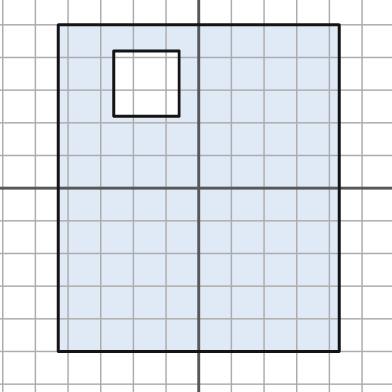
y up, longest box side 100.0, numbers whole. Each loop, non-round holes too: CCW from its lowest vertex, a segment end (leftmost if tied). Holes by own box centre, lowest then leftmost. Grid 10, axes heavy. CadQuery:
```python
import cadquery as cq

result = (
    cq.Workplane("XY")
    .moveTo(-43.0, -50.0)
    .lineTo(43.0, -50.0)
    .lineTo(43.0, 50.0)
    .lineTo(-43.0, 50.0)
    .close()
    .moveTo(-26.0, 22.0)
    .lineTo(-6.0, 22.0)
    .lineTo(-6.0, 42.0)
    .lineTo(-26.0, 42.0)
    .close()
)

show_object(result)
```